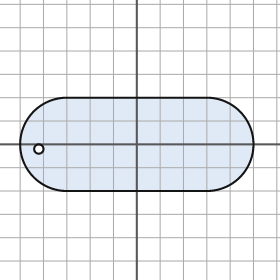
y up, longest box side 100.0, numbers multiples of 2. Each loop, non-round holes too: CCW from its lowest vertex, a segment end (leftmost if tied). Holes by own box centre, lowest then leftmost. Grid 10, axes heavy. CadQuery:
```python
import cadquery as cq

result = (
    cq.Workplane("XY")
    .moveTo(-30.0, -20.0)
    .lineTo(30.0, -20.0)
    .threePointArc((50.0, 0.0), (30.0, 20.0))
    .lineTo(-30.0, 20.0)
    .threePointArc((-50.0, 0.0), (-30.0, -20.0))
    .close()
    .moveTo(-42.0, -2.0)
    .circle(2.0)
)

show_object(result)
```